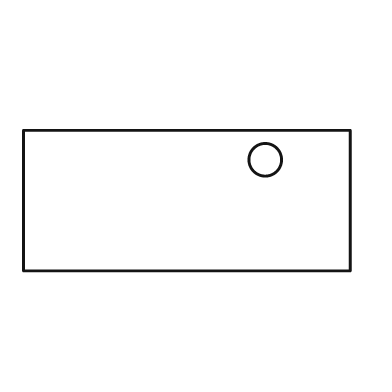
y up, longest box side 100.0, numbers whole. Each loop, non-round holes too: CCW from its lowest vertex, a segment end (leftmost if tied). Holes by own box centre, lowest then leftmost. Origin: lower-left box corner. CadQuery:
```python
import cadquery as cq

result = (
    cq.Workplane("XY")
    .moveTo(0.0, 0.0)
    .lineTo(100.0, 0.0)
    .lineTo(100.0, 43.0)
    .lineTo(0.0, 43.0)
    .close()
    .moveTo(74.0, 34.0)
    .circle(5.0)
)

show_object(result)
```